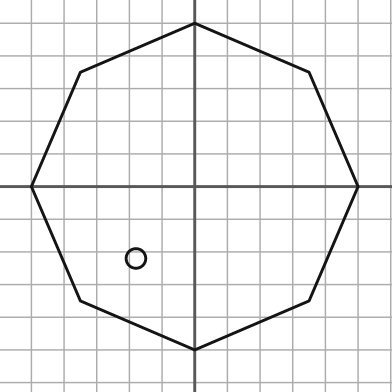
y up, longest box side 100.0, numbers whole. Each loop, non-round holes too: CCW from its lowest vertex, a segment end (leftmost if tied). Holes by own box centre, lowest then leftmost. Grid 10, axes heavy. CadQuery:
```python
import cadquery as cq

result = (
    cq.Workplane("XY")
    .moveTo(0.0, -50.0)
    .lineTo(35.0, -35.0)
    .lineTo(50.0, 0.0)
    .lineTo(35.0, 35.0)
    .lineTo(0.0, 50.0)
    .lineTo(-35.0, 35.0)
    .lineTo(-50.0, 0.0)
    .lineTo(-35.0, -35.0)
    .close()
    .moveTo(-18.0, -22.0)
    .circle(3.0)
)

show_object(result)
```